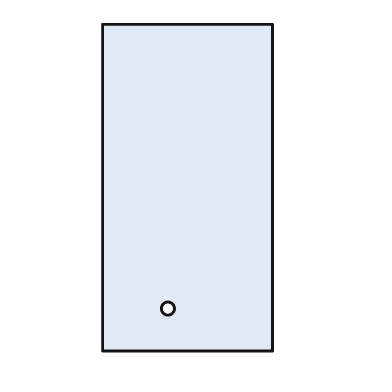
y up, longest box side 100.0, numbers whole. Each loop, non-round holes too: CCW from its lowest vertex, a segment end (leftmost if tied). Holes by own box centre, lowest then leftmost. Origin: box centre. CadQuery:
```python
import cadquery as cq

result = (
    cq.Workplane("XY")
    .moveTo(-26.0, -50.0)
    .lineTo(26.0, -50.0)
    .lineTo(26.0, 50.0)
    .lineTo(-26.0, 50.0)
    .close()
    .moveTo(-6.0, -37.0)
    .circle(2.0)
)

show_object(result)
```